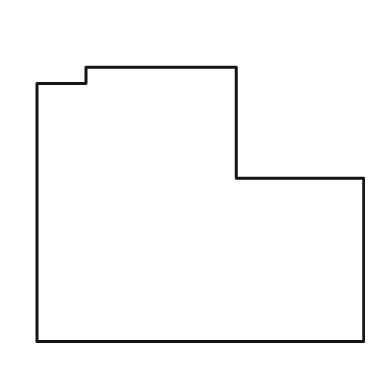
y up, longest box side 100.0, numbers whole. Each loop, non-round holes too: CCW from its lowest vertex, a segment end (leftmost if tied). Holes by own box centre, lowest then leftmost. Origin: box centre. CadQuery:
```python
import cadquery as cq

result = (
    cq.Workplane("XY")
    .moveTo(-50.0, -42.0)
    .lineTo(50.0, -42.0)
    .lineTo(50.0, 8.0)
    .lineTo(11.0, 8.0)
    .lineTo(11.0, 42.0)
    .lineTo(-35.0, 42.0)
    .lineTo(-35.0, 37.0)
    .lineTo(-50.0, 37.0)
    .close()
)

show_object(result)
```